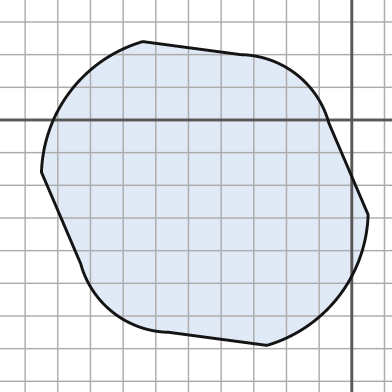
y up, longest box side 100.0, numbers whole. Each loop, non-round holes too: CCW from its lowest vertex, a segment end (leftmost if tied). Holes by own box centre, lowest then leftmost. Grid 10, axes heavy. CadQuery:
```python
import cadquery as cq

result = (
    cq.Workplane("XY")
    .moveTo(-26.0, -69.0)
    .threePointArc((-4.0, -54.0), (5.0, -29.0))
    .lineTo(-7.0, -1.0)
    .threePointArc((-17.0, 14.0), (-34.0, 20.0))
    .lineTo(-64.0, 24.0)
    .threePointArc((-86.0, 9.0), (-95.0, -16.0))
    .lineTo(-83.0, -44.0)
    .threePointArc((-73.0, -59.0), (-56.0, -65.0))
    .close()
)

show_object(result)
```